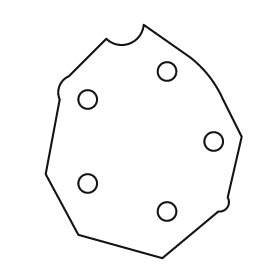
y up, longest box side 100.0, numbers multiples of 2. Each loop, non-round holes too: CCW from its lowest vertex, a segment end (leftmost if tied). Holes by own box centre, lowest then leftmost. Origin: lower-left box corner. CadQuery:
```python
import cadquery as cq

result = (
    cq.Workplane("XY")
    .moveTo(50.0, 0.0)
    .lineTo(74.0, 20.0)
    .threePointArc((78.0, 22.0), (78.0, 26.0))
    .lineTo(84.0, 52.0)
    .lineTo(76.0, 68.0)
    .threePointArc((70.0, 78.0), (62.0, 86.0))
    .lineTo(42.0, 100.0)
    .threePointArc((36.0, 92.0), (26.0, 94.0))
    .lineTo(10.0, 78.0)
    .threePointArc((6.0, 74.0), (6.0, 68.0))
    .lineTo(0.0, 36.0)
    .lineTo(14.0, 10.0)
    .close()
    .moveTo(52.0, 20.0)
    .circle(4.0)
    .moveTo(18.0, 32.0)
    .circle(4.0)
    .moveTo(72.0, 50.0)
    .circle(4.0)
    .moveTo(18.0, 68.0)
    .circle(4.0)
    .moveTo(52.0, 80.0)
    .circle(4.0)
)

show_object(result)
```